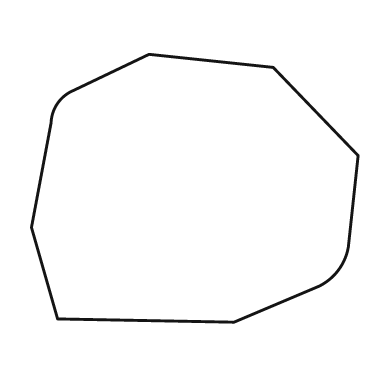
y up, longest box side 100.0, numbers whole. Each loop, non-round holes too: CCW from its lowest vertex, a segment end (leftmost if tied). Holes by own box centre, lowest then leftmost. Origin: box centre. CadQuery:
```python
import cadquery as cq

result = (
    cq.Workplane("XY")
    .moveTo(12.0, -41.0)
    .lineTo(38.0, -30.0)
    .threePointArc((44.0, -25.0), (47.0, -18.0))
    .lineTo(50.0, 10.0)
    .lineTo(24.0, 37.0)
    .lineTo(-14.0, 41.0)
    .lineTo(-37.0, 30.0)
    .threePointArc((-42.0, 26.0), (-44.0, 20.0))
    .lineTo(-50.0, -12.0)
    .lineTo(-42.0, -40.0)
    .close()
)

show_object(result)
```